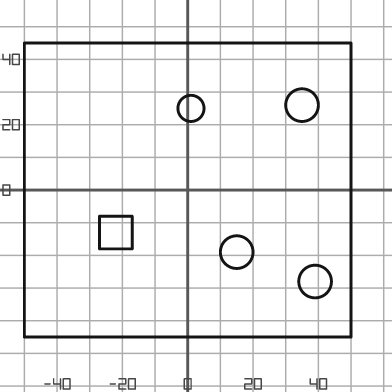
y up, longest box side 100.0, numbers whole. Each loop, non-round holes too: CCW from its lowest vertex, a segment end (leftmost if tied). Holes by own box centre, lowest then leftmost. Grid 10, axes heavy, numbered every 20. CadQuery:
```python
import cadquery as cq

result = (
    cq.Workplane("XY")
    .moveTo(-50.0, -45.0)
    .lineTo(50.0, -45.0)
    .lineTo(50.0, 45.0)
    .lineTo(-50.0, 45.0)
    .close()
    .moveTo(39.0, -28.0)
    .circle(5.0)
    .moveTo(15.0, -19.0)
    .circle(5.0)
    .moveTo(-27.0, -18.0)
    .lineTo(-17.0, -18.0)
    .lineTo(-17.0, -8.0)
    .lineTo(-27.0, -8.0)
    .close()
    .moveTo(1.0, 25.0)
    .circle(4.0)
    .moveTo(35.0, 26.0)
    .circle(5.0)
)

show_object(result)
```